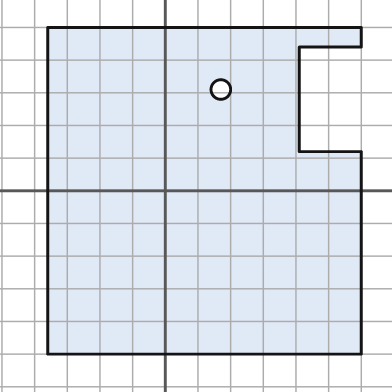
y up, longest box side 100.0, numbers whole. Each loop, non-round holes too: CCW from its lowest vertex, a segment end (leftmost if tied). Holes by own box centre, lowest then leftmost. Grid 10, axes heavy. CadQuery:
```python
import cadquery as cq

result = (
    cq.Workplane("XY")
    .moveTo(-36.0, -50.0)
    .lineTo(60.0, -50.0)
    .lineTo(60.0, 12.0)
    .lineTo(41.0, 12.0)
    .lineTo(41.0, 44.0)
    .lineTo(60.0, 44.0)
    .lineTo(60.0, 50.0)
    .lineTo(-36.0, 50.0)
    .close()
    .moveTo(17.0, 31.0)
    .circle(3.0)
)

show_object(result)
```